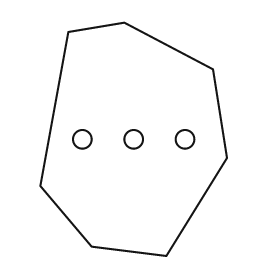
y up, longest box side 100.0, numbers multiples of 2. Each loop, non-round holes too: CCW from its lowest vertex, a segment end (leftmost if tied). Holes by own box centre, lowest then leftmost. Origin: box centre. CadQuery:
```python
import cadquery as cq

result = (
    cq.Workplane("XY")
    .moveTo(14.0, -50.0)
    .lineTo(40.0, -8.0)
    .lineTo(34.0, 30.0)
    .lineTo(-4.0, 50.0)
    .lineTo(-28.0, 46.0)
    .lineTo(-40.0, -20.0)
    .lineTo(-18.0, -46.0)
    .close()
    .moveTo(-22.0, 0.0)
    .circle(4.0)
    .moveTo(0.0, 0.0)
    .circle(4.0)
    .moveTo(22.0, 0.0)
    .circle(4.0)
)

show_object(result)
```